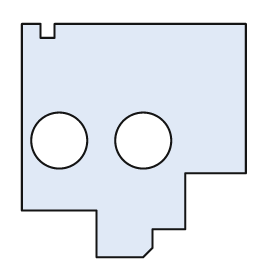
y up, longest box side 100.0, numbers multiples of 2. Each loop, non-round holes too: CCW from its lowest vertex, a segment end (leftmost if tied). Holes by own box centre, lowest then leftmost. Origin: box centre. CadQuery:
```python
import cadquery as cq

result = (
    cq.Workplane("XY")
    .moveTo(-16.0, -50.0)
    .lineTo(4.0, -50.0)
    .lineTo(8.0, -46.0)
    .lineTo(8.0, -38.0)
    .lineTo(22.0, -38.0)
    .lineTo(22.0, -14.0)
    .lineTo(48.0, -14.0)
    .lineTo(48.0, 50.0)
    .lineTo(-34.0, 50.0)
    .lineTo(-34.0, 44.0)
    .lineTo(-40.0, 44.0)
    .lineTo(-40.0, 50.0)
    .lineTo(-48.0, 50.0)
    .lineTo(-48.0, -30.0)
    .lineTo(-16.0, -30.0)
    .close()
    .moveTo(-32.0, 0.0)
    .circle(12.0)
    .moveTo(4.0, 0.0)
    .circle(12.0)
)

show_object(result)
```